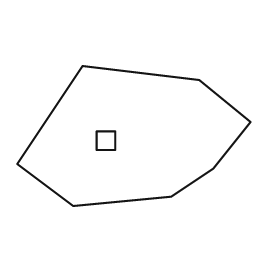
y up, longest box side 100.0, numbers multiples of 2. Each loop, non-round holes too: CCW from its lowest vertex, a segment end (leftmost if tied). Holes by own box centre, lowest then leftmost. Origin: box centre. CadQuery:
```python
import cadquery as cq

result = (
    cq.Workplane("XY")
    .moveTo(-26.0, -30.0)
    .lineTo(16.0, -26.0)
    .lineTo(34.0, -14.0)
    .lineTo(50.0, 6.0)
    .lineTo(28.0, 24.0)
    .lineTo(-22.0, 30.0)
    .lineTo(-50.0, -12.0)
    .close()
    .moveTo(-16.0, -6.0)
    .lineTo(-8.0, -6.0)
    .lineTo(-8.0, 2.0)
    .lineTo(-16.0, 2.0)
    .close()
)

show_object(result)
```